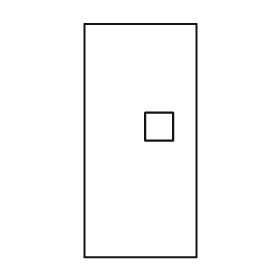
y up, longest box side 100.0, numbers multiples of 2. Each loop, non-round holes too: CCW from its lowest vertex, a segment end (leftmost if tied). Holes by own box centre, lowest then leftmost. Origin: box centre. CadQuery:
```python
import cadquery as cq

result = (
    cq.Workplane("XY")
    .moveTo(-24.0, -50.0)
    .lineTo(24.0, -50.0)
    .lineTo(24.0, 50.0)
    .lineTo(-24.0, 50.0)
    .close()
    .moveTo(2.0, 0.0)
    .lineTo(14.0, 0.0)
    .lineTo(14.0, 12.0)
    .lineTo(2.0, 12.0)
    .close()
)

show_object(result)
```